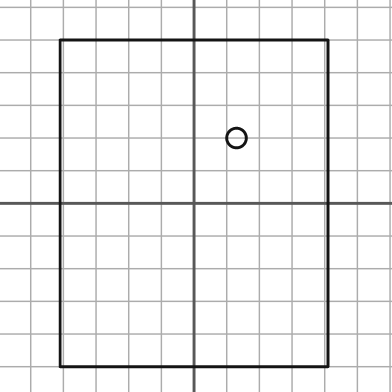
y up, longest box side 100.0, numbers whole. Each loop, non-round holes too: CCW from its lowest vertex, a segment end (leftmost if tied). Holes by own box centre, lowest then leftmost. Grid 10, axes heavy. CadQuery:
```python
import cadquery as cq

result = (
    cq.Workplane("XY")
    .moveTo(-41.0, -50.0)
    .lineTo(41.0, -50.0)
    .lineTo(41.0, 50.0)
    .lineTo(-41.0, 50.0)
    .close()
    .moveTo(13.0, 20.0)
    .circle(3.0)
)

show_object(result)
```